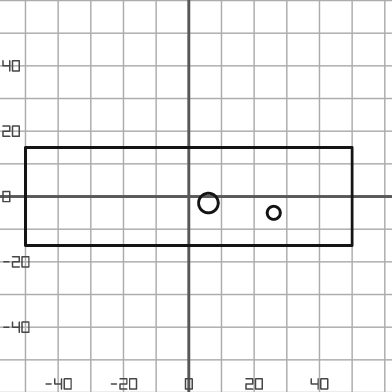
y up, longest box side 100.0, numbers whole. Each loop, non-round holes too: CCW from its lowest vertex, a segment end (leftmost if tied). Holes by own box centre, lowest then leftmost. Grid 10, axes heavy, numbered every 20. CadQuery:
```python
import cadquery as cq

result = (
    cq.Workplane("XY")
    .moveTo(-50.0, -15.0)
    .lineTo(50.0, -15.0)
    .lineTo(50.0, 15.0)
    .lineTo(-50.0, 15.0)
    .close()
    .moveTo(26.0, -5.0)
    .circle(2.0)
    .moveTo(6.0, -2.0)
    .circle(3.0)
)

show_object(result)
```